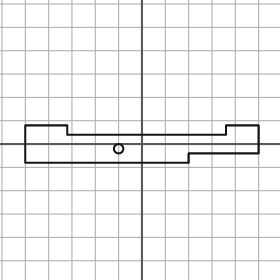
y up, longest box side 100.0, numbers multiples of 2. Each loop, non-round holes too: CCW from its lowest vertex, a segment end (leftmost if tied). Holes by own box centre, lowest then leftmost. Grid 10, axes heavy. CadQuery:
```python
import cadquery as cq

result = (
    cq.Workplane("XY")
    .moveTo(-50.0, -8.0)
    .lineTo(20.0, -8.0)
    .lineTo(20.0, -4.0)
    .lineTo(50.0, -4.0)
    .lineTo(50.0, 8.0)
    .lineTo(36.0, 8.0)
    .lineTo(36.0, 4.0)
    .lineTo(-32.0, 4.0)
    .lineTo(-32.0, 8.0)
    .lineTo(-50.0, 8.0)
    .close()
    .moveTo(-10.0, -2.0)
    .circle(2.0)
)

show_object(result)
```